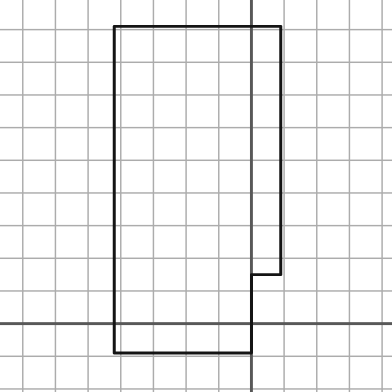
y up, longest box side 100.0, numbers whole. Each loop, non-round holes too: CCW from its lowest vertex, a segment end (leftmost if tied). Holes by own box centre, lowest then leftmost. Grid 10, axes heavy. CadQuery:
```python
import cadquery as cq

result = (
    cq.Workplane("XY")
    .moveTo(-42.0, -9.0)
    .lineTo(0.0, -9.0)
    .lineTo(0.0, 15.0)
    .lineTo(9.0, 15.0)
    .lineTo(9.0, 91.0)
    .lineTo(-42.0, 91.0)
    .close()
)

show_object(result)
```